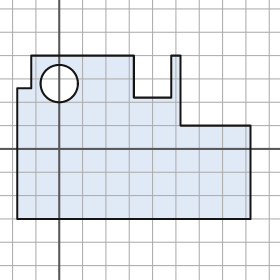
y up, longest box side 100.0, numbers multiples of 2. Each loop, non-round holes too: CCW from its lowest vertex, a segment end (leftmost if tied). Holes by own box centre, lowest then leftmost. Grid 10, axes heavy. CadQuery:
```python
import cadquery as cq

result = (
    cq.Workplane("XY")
    .moveTo(-18.0, -30.0)
    .lineTo(82.0, -30.0)
    .lineTo(82.0, 10.0)
    .lineTo(52.0, 10.0)
    .lineTo(52.0, 40.0)
    .lineTo(48.0, 40.0)
    .lineTo(48.0, 22.0)
    .lineTo(32.0, 22.0)
    .lineTo(32.0, 40.0)
    .lineTo(-12.0, 40.0)
    .lineTo(-12.0, 26.0)
    .lineTo(-18.0, 26.0)
    .close()
    .moveTo(0.0, 28.0)
    .circle(8.0)
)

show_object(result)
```